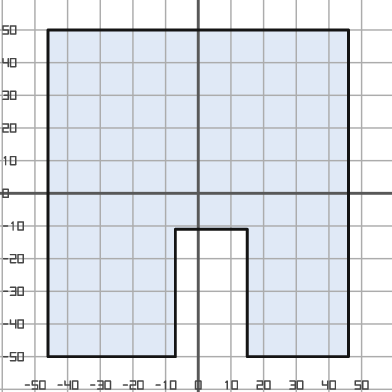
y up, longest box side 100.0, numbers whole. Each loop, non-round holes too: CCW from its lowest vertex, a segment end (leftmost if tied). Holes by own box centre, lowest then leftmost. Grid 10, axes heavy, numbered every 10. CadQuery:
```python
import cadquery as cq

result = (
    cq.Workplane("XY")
    .moveTo(-46.0, -50.0)
    .lineTo(-7.0, -50.0)
    .lineTo(-7.0, -11.0)
    .lineTo(15.0, -11.0)
    .lineTo(15.0, -50.0)
    .lineTo(46.0, -50.0)
    .lineTo(46.0, 50.0)
    .lineTo(-46.0, 50.0)
    .close()
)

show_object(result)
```